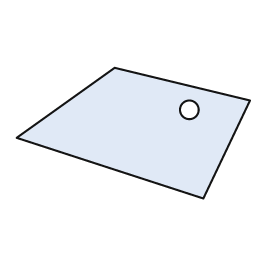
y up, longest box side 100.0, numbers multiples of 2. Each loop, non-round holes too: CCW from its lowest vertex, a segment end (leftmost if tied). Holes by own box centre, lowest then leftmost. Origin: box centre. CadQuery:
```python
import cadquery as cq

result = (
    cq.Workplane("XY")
    .moveTo(30.0, -28.0)
    .lineTo(50.0, 14.0)
    .lineTo(-8.0, 28.0)
    .lineTo(-50.0, -2.0)
    .close()
    .moveTo(24.0, 10.0)
    .circle(4.0)
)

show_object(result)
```